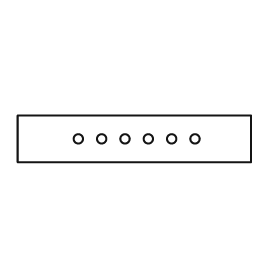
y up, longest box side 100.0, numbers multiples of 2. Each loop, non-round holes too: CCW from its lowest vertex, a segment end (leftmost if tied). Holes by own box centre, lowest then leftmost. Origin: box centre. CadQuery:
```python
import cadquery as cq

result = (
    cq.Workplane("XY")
    .moveTo(-50.0, -10.0)
    .lineTo(50.0, -10.0)
    .lineTo(50.0, 10.0)
    .lineTo(-50.0, 10.0)
    .close()
    .moveTo(-24.0, 0.0)
    .circle(2.0)
    .moveTo(-14.0, 0.0)
    .circle(2.0)
    .moveTo(-4.0, 0.0)
    .circle(2.0)
    .moveTo(6.0, 0.0)
    .circle(2.0)
    .moveTo(16.0, 0.0)
    .circle(2.0)
    .moveTo(26.0, 0.0)
    .circle(2.0)
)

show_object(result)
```